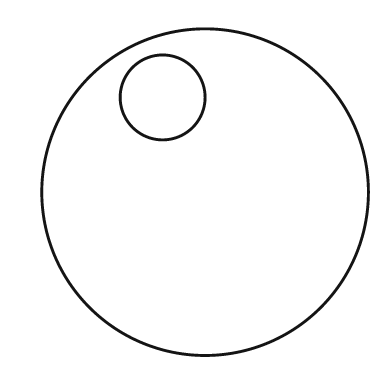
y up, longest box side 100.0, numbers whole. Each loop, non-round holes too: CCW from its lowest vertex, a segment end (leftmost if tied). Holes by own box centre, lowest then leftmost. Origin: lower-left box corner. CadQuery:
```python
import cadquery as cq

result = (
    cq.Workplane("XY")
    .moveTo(50.0, 50.0)
    .circle(50.0)
    .moveTo(37.0, 79.0)
    .circle(13.0)
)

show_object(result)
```